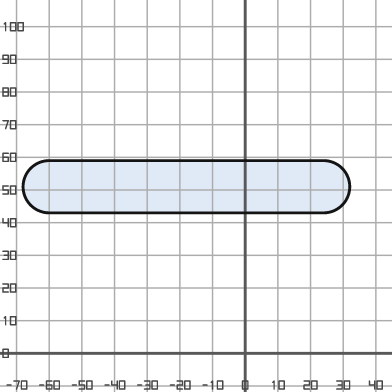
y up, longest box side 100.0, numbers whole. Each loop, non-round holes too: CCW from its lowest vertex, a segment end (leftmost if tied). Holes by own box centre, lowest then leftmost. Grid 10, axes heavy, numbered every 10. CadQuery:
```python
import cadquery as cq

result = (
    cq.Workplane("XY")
    .moveTo(-60.0, 43.0)
    .lineTo(24.0, 43.0)
    .threePointArc((32.0, 51.0), (24.0, 59.0))
    .lineTo(-60.0, 59.0)
    .threePointArc((-68.0, 51.0), (-60.0, 43.0))
    .close()
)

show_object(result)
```